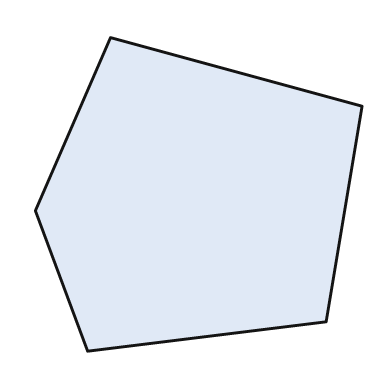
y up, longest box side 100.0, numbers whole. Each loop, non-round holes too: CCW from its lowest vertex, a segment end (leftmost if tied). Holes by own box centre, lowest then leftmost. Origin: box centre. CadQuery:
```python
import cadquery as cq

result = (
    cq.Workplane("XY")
    .moveTo(-34.0, -48.0)
    .lineTo(39.0, -39.0)
    .lineTo(50.0, 27.0)
    .lineTo(-27.0, 48.0)
    .lineTo(-50.0, -5.0)
    .close()
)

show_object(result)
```